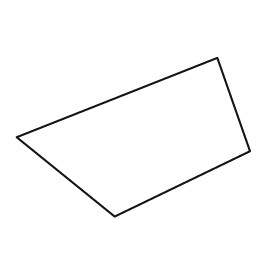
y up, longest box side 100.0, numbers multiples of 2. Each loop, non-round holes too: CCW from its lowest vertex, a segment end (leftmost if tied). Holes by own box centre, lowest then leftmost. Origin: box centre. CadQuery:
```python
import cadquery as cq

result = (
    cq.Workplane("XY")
    .moveTo(-8.0, -34.0)
    .lineTo(50.0, -6.0)
    .lineTo(36.0, 34.0)
    .lineTo(-50.0, 0.0)
    .close()
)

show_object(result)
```